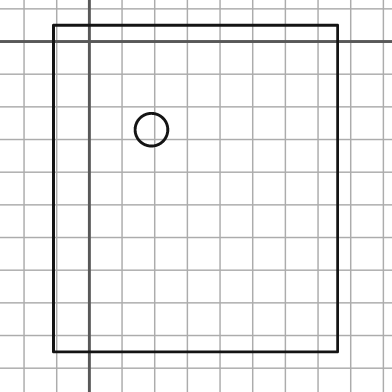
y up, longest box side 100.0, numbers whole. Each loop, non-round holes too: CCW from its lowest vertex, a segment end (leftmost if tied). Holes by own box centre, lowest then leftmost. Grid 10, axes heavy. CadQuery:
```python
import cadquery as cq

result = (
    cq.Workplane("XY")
    .moveTo(-11.0, -95.0)
    .lineTo(76.0, -95.0)
    .lineTo(76.0, 5.0)
    .lineTo(-11.0, 5.0)
    .close()
    .moveTo(19.0, -27.0)
    .circle(5.0)
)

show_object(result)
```